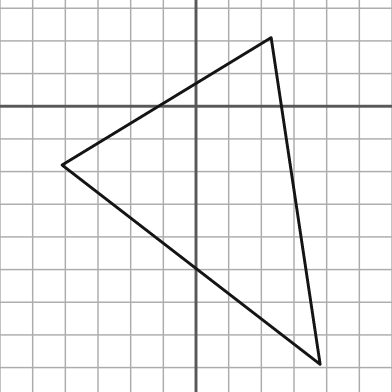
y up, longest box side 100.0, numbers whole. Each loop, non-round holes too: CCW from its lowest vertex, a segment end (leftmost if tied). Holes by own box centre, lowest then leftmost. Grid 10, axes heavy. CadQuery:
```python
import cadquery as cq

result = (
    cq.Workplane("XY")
    .moveTo(38.0, -79.0)
    .lineTo(23.0, 21.0)
    .lineTo(-41.0, -18.0)
    .close()
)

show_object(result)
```